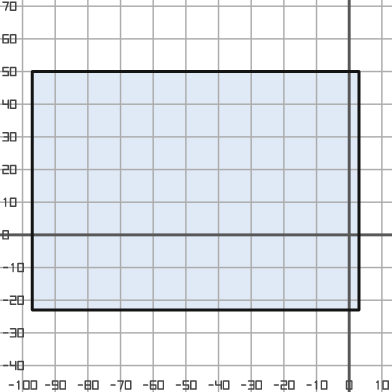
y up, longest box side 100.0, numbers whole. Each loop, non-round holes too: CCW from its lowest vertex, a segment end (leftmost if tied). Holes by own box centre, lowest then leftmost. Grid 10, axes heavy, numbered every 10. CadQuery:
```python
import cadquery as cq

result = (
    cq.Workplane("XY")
    .moveTo(-97.0, -23.0)
    .lineTo(3.0, -23.0)
    .lineTo(3.0, 50.0)
    .lineTo(-97.0, 50.0)
    .close()
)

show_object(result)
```